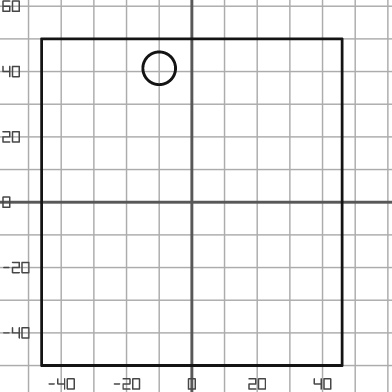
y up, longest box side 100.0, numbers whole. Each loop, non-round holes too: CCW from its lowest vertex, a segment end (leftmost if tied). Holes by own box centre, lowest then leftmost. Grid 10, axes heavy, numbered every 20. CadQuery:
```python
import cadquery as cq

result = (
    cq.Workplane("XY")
    .moveTo(-46.0, -50.0)
    .lineTo(46.0, -50.0)
    .lineTo(46.0, 50.0)
    .lineTo(-46.0, 50.0)
    .close()
    .moveTo(-10.0, 41.0)
    .circle(5.0)
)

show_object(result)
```